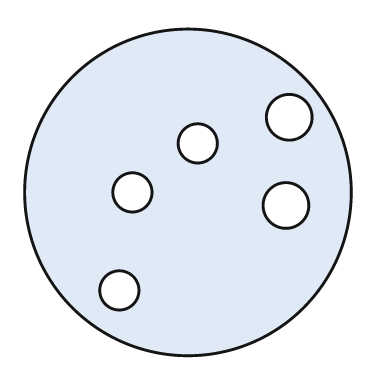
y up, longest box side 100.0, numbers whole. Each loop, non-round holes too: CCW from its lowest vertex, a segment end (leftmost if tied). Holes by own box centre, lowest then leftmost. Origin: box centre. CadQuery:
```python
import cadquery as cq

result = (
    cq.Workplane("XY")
    .moveTo(0.0, 0.0)
    .circle(50.0)
    .moveTo(-21.0, -30.0)
    .circle(6.0)
    .moveTo(30.0, -4.0)
    .circle(7.0)
    .moveTo(-17.0, 0.0)
    .circle(6.0)
    .moveTo(3.0, 15.0)
    .circle(6.0)
    .moveTo(31.0, 23.0)
    .circle(7.0)
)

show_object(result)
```